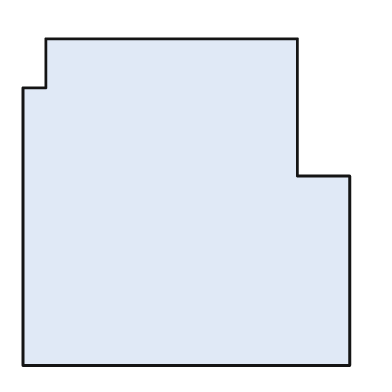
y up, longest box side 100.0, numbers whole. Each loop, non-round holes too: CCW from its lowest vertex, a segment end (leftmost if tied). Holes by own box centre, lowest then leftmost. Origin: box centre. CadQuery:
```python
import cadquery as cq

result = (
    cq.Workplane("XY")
    .moveTo(-50.0, -50.0)
    .lineTo(50.0, -50.0)
    .lineTo(50.0, 8.0)
    .lineTo(34.0, 8.0)
    .lineTo(34.0, 50.0)
    .lineTo(-43.0, 50.0)
    .lineTo(-43.0, 35.0)
    .lineTo(-50.0, 35.0)
    .close()
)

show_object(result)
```